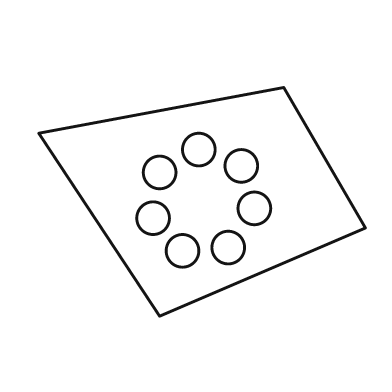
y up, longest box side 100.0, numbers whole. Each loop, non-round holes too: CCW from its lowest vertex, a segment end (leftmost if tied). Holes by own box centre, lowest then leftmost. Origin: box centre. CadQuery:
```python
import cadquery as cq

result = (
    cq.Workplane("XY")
    .moveTo(-13.0, -35.0)
    .lineTo(50.0, -8.0)
    .lineTo(25.0, 35.0)
    .lineTo(-50.0, 21.0)
    .close()
    .moveTo(-6.0, -15.0)
    .circle(5.0)
    .moveTo(8.0, -14.0)
    .circle(5.0)
    .moveTo(-15.0, -5.0)
    .circle(5.0)
    .moveTo(16.0, -2.0)
    .circle(5.0)
    .moveTo(-13.0, 9.0)
    .circle(5.0)
    .moveTo(12.0, 11.0)
    .circle(5.0)
    .moveTo(-1.0, 16.0)
    .circle(5.0)
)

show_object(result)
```